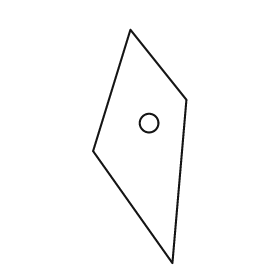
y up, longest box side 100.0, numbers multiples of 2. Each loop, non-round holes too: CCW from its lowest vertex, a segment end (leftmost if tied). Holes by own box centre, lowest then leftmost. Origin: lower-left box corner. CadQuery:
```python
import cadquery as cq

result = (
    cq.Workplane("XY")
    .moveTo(34.0, 0.0)
    .lineTo(40.0, 70.0)
    .lineTo(16.0, 100.0)
    .lineTo(0.0, 48.0)
    .close()
    .moveTo(24.0, 60.0)
    .circle(4.0)
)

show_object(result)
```